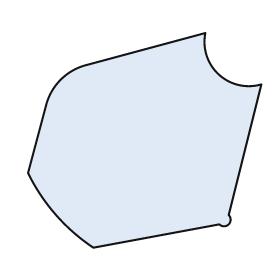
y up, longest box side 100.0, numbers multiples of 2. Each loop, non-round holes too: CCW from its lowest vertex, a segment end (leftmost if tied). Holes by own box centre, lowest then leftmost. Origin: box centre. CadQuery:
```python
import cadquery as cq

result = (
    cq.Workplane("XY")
    .moveTo(-22.0, -46.0)
    .lineTo(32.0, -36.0)
    .threePointArc((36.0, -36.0), (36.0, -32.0))
    .lineTo(50.0, 24.0)
    .threePointArc((32.0, 28.0), (26.0, 46.0))
    .lineTo(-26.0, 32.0)
    .threePointArc((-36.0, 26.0), (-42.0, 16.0))
    .lineTo(-50.0, -14.0)
    .threePointArc((-38.0, -32.0), (-22.0, -46.0))
    .close()
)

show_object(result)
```